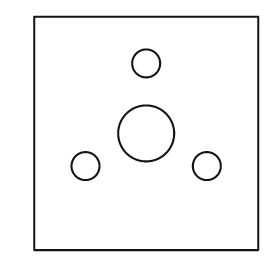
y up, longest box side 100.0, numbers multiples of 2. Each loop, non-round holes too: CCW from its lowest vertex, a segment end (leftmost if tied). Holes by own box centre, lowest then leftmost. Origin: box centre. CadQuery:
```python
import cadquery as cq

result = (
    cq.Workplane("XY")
    .moveTo(-48.0, -50.0)
    .lineTo(48.0, -50.0)
    .lineTo(48.0, 50.0)
    .lineTo(-48.0, 50.0)
    .close()
    .moveTo(-26.0, -14.0)
    .circle(6.0)
    .moveTo(26.0, -14.0)
    .circle(6.0)
    .moveTo(0.0, 0.0)
    .circle(12.0)
    .moveTo(0.0, 30.0)
    .circle(6.0)
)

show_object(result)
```